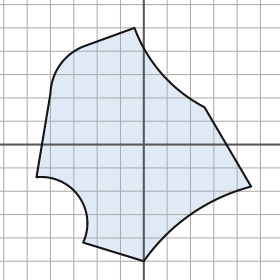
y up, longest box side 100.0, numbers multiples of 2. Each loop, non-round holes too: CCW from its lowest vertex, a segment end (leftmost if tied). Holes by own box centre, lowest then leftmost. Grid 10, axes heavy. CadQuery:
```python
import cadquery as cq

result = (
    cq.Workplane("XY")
    .moveTo(0.0, -50.0)
    .threePointArc((20.0, -30.0), (46.0, -18.0))
    .lineTo(26.0, 16.0)
    .threePointArc((8.0, 30.0), (-4.0, 50.0))
    .lineTo(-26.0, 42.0)
    .threePointArc((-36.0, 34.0), (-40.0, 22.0))
    .lineTo(-46.0, -14.0)
    .threePointArc((-28.0, -22.0), (-26.0, -42.0))
    .close()
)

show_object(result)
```